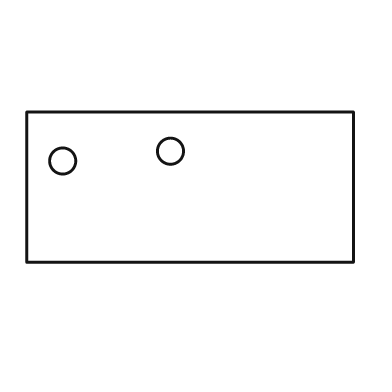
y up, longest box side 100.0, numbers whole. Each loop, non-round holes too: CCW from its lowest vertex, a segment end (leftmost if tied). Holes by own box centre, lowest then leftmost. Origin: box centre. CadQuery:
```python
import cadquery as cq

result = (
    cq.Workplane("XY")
    .moveTo(-50.0, -23.0)
    .lineTo(50.0, -23.0)
    .lineTo(50.0, 23.0)
    .lineTo(-50.0, 23.0)
    .close()
    .moveTo(-39.0, 8.0)
    .circle(4.0)
    .moveTo(-6.0, 11.0)
    .circle(4.0)
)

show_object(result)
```